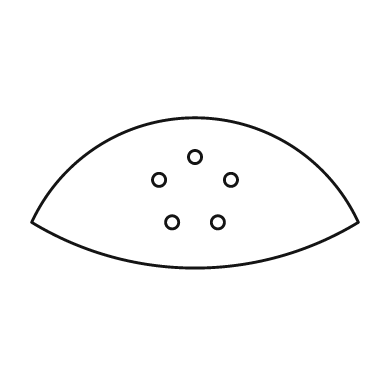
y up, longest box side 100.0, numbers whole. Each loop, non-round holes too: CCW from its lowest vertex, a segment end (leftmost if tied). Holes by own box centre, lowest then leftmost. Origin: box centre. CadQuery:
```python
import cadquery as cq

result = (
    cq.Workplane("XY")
    .moveTo(-50.0, -9.0)
    .threePointArc((0.0, -23.0), (50.0, -9.0))
    .threePointArc((0.0, 23.0), (-50.0, -9.0))
    .close()
    .moveTo(-7.0, -9.0)
    .circle(2.0)
    .moveTo(7.0, -9.0)
    .circle(2.0)
    .moveTo(-11.0, 4.0)
    .circle(2.0)
    .moveTo(11.0, 4.0)
    .circle(2.0)
    .moveTo(0.0, 11.0)
    .circle(2.0)
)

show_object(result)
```